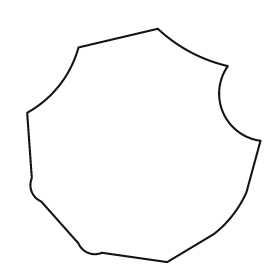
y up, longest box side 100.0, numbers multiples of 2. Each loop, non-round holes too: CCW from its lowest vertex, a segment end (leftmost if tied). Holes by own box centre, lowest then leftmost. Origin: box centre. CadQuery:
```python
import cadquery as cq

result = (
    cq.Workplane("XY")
    .moveTo(10.0, -50.0)
    .lineTo(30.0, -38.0)
    .threePointArc((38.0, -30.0), (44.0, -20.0))
    .lineTo(50.0, 2.0)
    .threePointArc((34.0, 14.0), (36.0, 34.0))
    .threePointArc((20.0, 40.0), (6.0, 50.0))
    .lineTo(-28.0, 42.0)
    .threePointArc((-36.0, 26.0), (-50.0, 14.0))
    .lineTo(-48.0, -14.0)
    .threePointArc((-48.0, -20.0), (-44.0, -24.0))
    .lineTo(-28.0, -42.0)
    .threePointArc((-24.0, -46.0), (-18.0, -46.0))
    .close()
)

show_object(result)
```